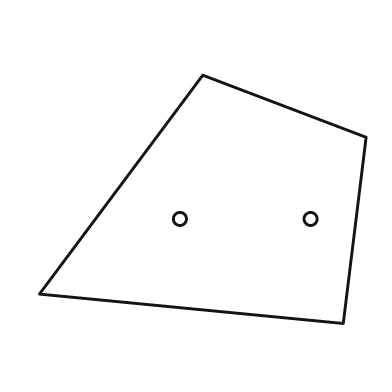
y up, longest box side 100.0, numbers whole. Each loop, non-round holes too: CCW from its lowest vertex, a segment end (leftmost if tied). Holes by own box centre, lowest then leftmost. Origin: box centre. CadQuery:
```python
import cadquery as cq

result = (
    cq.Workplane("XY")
    .moveTo(43.0, -38.0)
    .lineTo(50.0, 19.0)
    .lineTo(0.0, 38.0)
    .lineTo(-50.0, -29.0)
    .close()
    .moveTo(-7.0, -6.0)
    .circle(2.0)
    .moveTo(33.0, -6.0)
    .circle(2.0)
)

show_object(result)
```